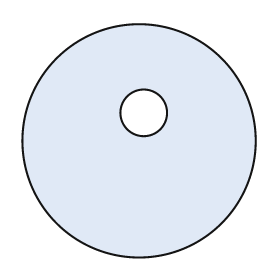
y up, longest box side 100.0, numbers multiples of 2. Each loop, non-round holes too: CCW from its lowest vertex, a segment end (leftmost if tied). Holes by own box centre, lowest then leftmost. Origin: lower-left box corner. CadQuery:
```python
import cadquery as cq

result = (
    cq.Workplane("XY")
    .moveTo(50.0, 50.0)
    .circle(50.0)
    .moveTo(52.0, 62.0)
    .circle(10.0)
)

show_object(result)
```